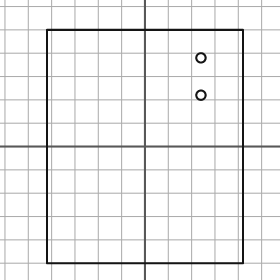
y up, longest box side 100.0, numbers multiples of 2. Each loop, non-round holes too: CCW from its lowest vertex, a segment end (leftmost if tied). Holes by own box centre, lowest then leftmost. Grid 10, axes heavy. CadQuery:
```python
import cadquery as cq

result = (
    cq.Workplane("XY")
    .moveTo(-42.0, -50.0)
    .lineTo(42.0, -50.0)
    .lineTo(42.0, 50.0)
    .lineTo(-42.0, 50.0)
    .close()
    .moveTo(24.0, 22.0)
    .circle(2.0)
    .moveTo(24.0, 38.0)
    .circle(2.0)
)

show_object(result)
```